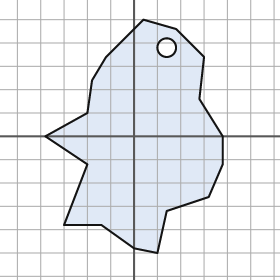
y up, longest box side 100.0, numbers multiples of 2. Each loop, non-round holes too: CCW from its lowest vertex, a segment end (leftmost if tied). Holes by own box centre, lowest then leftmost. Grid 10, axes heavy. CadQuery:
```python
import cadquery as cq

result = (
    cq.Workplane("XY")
    .moveTo(10.0, -50.0)
    .lineTo(14.0, -32.0)
    .lineTo(32.0, -26.0)
    .lineTo(38.0, -12.0)
    .lineTo(38.0, 0.0)
    .lineTo(28.0, 16.0)
    .lineTo(30.0, 34.0)
    .lineTo(18.0, 46.0)
    .lineTo(4.0, 50.0)
    .lineTo(-12.0, 34.0)
    .lineTo(-18.0, 24.0)
    .lineTo(-20.0, 10.0)
    .lineTo(-38.0, 0.0)
    .lineTo(-20.0, -12.0)
    .lineTo(-30.0, -38.0)
    .lineTo(-14.0, -38.0)
    .lineTo(0.0, -48.0)
    .close()
    .moveTo(14.0, 38.0)
    .circle(4.0)
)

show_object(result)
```